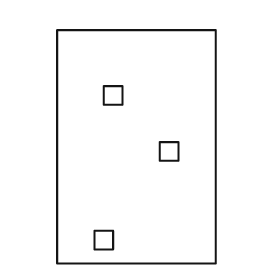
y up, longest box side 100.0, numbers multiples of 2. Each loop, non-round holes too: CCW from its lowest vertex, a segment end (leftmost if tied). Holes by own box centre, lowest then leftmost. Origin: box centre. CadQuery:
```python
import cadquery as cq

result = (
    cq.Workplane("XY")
    .moveTo(-34.0, -50.0)
    .lineTo(34.0, -50.0)
    .lineTo(34.0, 50.0)
    .lineTo(-34.0, 50.0)
    .close()
    .moveTo(-18.0, -44.0)
    .lineTo(-10.0, -44.0)
    .lineTo(-10.0, -36.0)
    .lineTo(-18.0, -36.0)
    .close()
    .moveTo(10.0, -6.0)
    .lineTo(18.0, -6.0)
    .lineTo(18.0, 2.0)
    .lineTo(10.0, 2.0)
    .close()
    .moveTo(-14.0, 18.0)
    .lineTo(-6.0, 18.0)
    .lineTo(-6.0, 26.0)
    .lineTo(-14.0, 26.0)
    .close()
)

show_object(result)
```